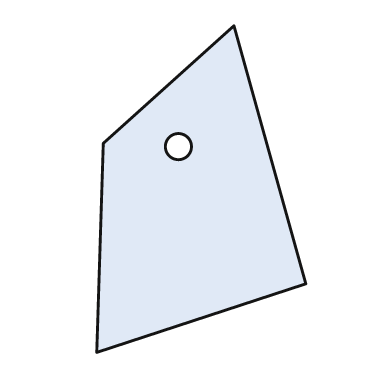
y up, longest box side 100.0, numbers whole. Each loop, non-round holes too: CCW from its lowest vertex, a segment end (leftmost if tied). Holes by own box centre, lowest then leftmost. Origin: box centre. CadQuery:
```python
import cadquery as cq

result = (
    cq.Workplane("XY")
    .moveTo(-32.0, -50.0)
    .lineTo(32.0, -29.0)
    .lineTo(10.0, 50.0)
    .lineTo(-30.0, 14.0)
    .close()
    .moveTo(-7.0, 13.0)
    .circle(4.0)
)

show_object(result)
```